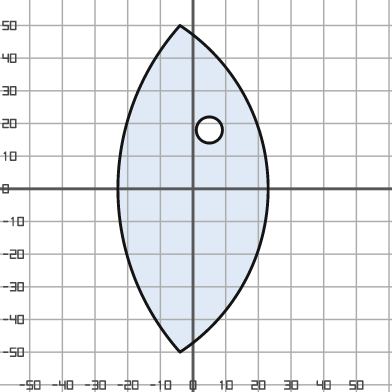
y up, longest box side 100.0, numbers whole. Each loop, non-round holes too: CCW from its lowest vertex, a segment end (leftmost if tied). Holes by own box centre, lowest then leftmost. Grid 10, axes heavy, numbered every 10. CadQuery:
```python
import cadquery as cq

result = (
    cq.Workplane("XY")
    .moveTo(-4.0, -50.0)
    .threePointArc((23.0, 0.0), (-4.0, 50.0))
    .threePointArc((-23.0, 0.0), (-4.0, -50.0))
    .close()
    .moveTo(5.0, 18.0)
    .circle(4.0)
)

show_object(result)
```